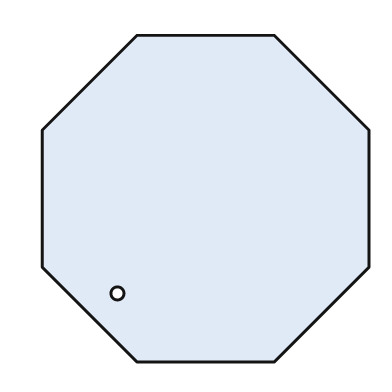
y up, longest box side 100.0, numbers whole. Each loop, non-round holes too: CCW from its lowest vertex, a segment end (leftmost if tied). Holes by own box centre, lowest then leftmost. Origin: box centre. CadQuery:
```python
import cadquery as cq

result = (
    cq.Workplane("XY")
    .moveTo(-21.0, -50.0)
    .lineTo(21.0, -50.0)
    .lineTo(50.0, -21.0)
    .lineTo(50.0, 21.0)
    .lineTo(21.0, 50.0)
    .lineTo(-21.0, 50.0)
    .lineTo(-50.0, 21.0)
    .lineTo(-50.0, -21.0)
    .close()
    .moveTo(-27.0, -29.0)
    .circle(2.0)
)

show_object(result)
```